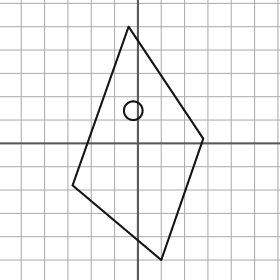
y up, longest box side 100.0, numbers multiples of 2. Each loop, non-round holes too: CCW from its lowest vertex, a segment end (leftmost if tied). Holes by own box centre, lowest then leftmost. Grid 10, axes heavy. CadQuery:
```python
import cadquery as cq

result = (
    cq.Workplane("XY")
    .moveTo(10.0, -50.0)
    .lineTo(28.0, 2.0)
    .lineTo(-4.0, 50.0)
    .lineTo(-28.0, -18.0)
    .close()
    .moveTo(-2.0, 14.0)
    .circle(4.0)
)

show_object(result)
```